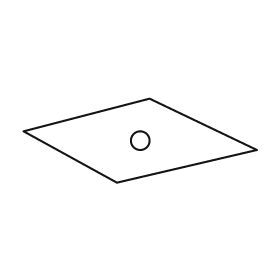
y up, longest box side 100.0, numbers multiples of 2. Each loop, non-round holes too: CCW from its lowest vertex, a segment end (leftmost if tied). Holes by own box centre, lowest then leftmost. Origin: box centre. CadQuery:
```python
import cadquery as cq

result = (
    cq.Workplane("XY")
    .moveTo(-10.0, -18.0)
    .lineTo(50.0, -4.0)
    .lineTo(4.0, 18.0)
    .lineTo(-50.0, 4.0)
    .close()
    .moveTo(0.0, 0.0)
    .circle(4.0)
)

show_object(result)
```